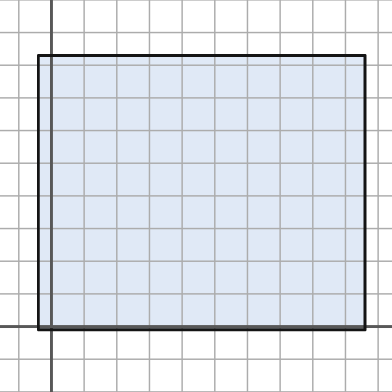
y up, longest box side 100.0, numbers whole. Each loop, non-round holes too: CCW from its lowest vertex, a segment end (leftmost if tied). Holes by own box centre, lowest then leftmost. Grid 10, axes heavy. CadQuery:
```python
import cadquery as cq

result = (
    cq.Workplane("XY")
    .moveTo(-4.0, -1.0)
    .lineTo(96.0, -1.0)
    .lineTo(96.0, 83.0)
    .lineTo(-4.0, 83.0)
    .close()
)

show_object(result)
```